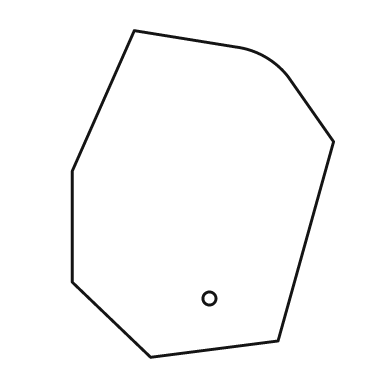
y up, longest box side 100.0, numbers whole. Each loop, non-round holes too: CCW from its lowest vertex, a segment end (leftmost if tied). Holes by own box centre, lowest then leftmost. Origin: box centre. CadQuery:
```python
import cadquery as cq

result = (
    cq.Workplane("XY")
    .moveTo(-16.0, -50.0)
    .lineTo(23.0, -45.0)
    .lineTo(40.0, 16.0)
    .lineTo(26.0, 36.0)
    .threePointArc((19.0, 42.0), (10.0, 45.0))
    .lineTo(-21.0, 50.0)
    .lineTo(-40.0, 7.0)
    .lineTo(-40.0, -27.0)
    .close()
    .moveTo(2.0, -32.0)
    .circle(2.0)
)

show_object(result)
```